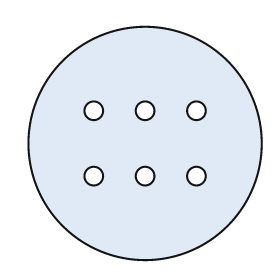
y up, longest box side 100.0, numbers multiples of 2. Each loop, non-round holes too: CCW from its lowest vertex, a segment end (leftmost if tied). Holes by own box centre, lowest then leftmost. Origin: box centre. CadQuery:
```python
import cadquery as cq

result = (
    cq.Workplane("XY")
    .moveTo(0.0, 0.0)
    .circle(50.0)
    .moveTo(-22.0, -14.0)
    .circle(4.0)
    .moveTo(0.0, -14.0)
    .circle(4.0)
    .moveTo(22.0, -14.0)
    .circle(4.0)
    .moveTo(-22.0, 14.0)
    .circle(4.0)
    .moveTo(0.0, 14.0)
    .circle(4.0)
    .moveTo(22.0, 14.0)
    .circle(4.0)
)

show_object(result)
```